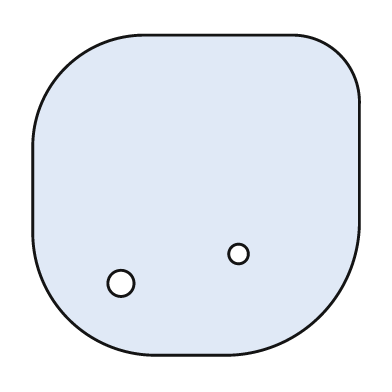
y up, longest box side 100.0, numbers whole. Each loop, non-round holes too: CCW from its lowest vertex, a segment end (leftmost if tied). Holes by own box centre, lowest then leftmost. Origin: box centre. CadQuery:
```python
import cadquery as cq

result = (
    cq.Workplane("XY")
    .moveTo(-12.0, -49.0)
    .lineTo(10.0, -49.0)
    .threePointArc((38.0, -37.0), (50.0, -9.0))
    .lineTo(50.0, 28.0)
    .threePointArc((44.0, 43.0), (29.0, 49.0))
    .lineTo(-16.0, 49.0)
    .threePointArc((-40.0, 39.0), (-50.0, 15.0))
    .lineTo(-50.0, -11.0)
    .threePointArc((-39.0, -38.0), (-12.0, -49.0))
    .close()
    .moveTo(-23.0, -27.0)
    .circle(4.0)
    .moveTo(13.0, -18.0)
    .circle(3.0)
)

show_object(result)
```